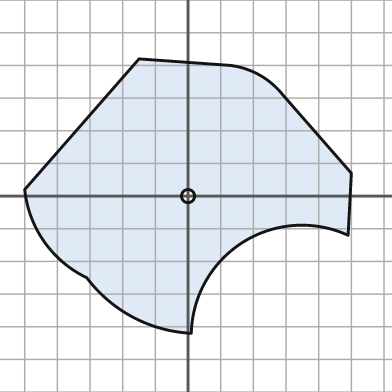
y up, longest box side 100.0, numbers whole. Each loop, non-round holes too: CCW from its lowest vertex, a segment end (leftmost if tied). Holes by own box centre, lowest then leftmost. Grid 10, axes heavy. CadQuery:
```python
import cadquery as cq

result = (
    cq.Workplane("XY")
    .moveTo(1.0, -42.0)
    .threePointArc((17.0, -14.0), (49.0, -12.0))
    .lineTo(50.0, 7.0)
    .lineTo(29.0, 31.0)
    .threePointArc((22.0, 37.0), (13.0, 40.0))
    .lineTo(-15.0, 42.0)
    .lineTo(-50.0, 2.0)
    .threePointArc((-44.0, -14.0), (-31.0, -25.0))
    .threePointArc((-17.0, -37.0), (1.0, -42.0))
    .close()
    .moveTo(0.0, 0.0)
    .circle(2.0)
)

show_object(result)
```